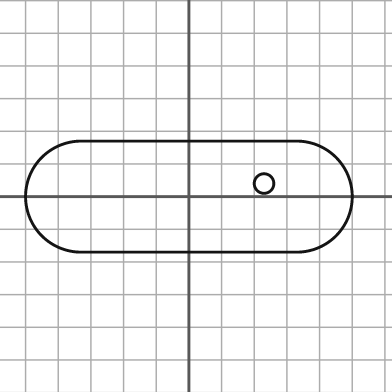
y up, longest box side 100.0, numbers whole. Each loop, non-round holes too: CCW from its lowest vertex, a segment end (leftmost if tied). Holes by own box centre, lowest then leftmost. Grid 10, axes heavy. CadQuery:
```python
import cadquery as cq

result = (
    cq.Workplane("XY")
    .moveTo(-33.0, -17.0)
    .lineTo(33.0, -17.0)
    .threePointArc((50.0, 0.0), (33.0, 17.0))
    .lineTo(-33.0, 17.0)
    .threePointArc((-50.0, 0.0), (-33.0, -17.0))
    .close()
    .moveTo(23.0, 4.0)
    .circle(3.0)
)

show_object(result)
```